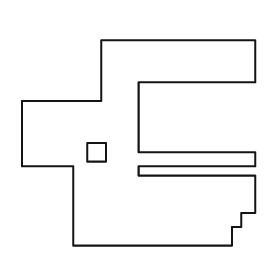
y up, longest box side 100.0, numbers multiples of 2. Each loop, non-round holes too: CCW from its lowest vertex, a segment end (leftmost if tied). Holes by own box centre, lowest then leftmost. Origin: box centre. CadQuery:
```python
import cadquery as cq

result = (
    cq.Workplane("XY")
    .moveTo(-28.0, -44.0)
    .lineTo(40.0, -44.0)
    .lineTo(40.0, -36.0)
    .lineTo(44.0, -36.0)
    .lineTo(44.0, -30.0)
    .lineTo(50.0, -30.0)
    .lineTo(50.0, -14.0)
    .lineTo(0.0, -14.0)
    .lineTo(0.0, -10.0)
    .lineTo(50.0, -10.0)
    .lineTo(50.0, -4.0)
    .lineTo(0.0, -4.0)
    .lineTo(0.0, 26.0)
    .lineTo(50.0, 26.0)
    .lineTo(50.0, 44.0)
    .lineTo(-16.0, 44.0)
    .lineTo(-16.0, 18.0)
    .lineTo(-50.0, 18.0)
    .lineTo(-50.0, -10.0)
    .lineTo(-28.0, -10.0)
    .close()
    .moveTo(-22.0, -8.0)
    .lineTo(-14.0, -8.0)
    .lineTo(-14.0, 0.0)
    .lineTo(-22.0, 0.0)
    .close()
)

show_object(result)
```